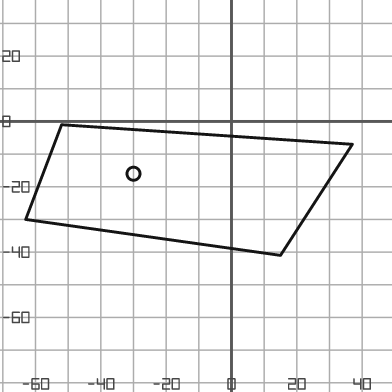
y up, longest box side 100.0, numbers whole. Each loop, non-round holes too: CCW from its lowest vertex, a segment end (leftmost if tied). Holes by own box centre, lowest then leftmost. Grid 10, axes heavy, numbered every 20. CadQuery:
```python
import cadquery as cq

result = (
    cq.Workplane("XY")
    .moveTo(15.0, -41.0)
    .lineTo(37.0, -7.0)
    .lineTo(-52.0, -1.0)
    .lineTo(-63.0, -30.0)
    .close()
    .moveTo(-30.0, -16.0)
    .circle(2.0)
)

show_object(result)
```